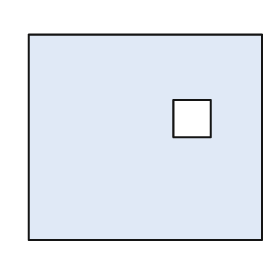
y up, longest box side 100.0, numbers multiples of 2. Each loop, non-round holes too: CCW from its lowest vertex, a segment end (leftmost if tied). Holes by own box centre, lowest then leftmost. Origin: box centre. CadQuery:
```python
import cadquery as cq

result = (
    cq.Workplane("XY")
    .moveTo(-50.0, -44.0)
    .lineTo(50.0, -44.0)
    .lineTo(50.0, 44.0)
    .lineTo(-50.0, 44.0)
    .close()
    .moveTo(12.0, 0.0)
    .lineTo(28.0, 0.0)
    .lineTo(28.0, 16.0)
    .lineTo(12.0, 16.0)
    .close()
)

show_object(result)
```